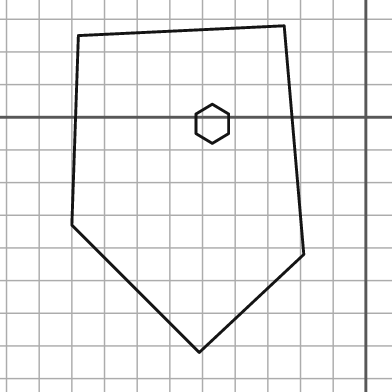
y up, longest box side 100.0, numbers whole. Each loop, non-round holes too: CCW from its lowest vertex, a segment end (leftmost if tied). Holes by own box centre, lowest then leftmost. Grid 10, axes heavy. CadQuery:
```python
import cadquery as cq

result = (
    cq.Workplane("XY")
    .moveTo(-51.0, -72.0)
    .lineTo(-19.0, -42.0)
    .lineTo(-25.0, 28.0)
    .lineTo(-88.0, 25.0)
    .lineTo(-90.0, -33.0)
    .close()
    .moveTo(-47.0, -8.0)
    .lineTo(-42.0, -5.0)
    .lineTo(-42.0, 1.0)
    .lineTo(-47.0, 4.0)
    .lineTo(-52.0, 1.0)
    .lineTo(-52.0, -5.0)
    .close()
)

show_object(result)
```